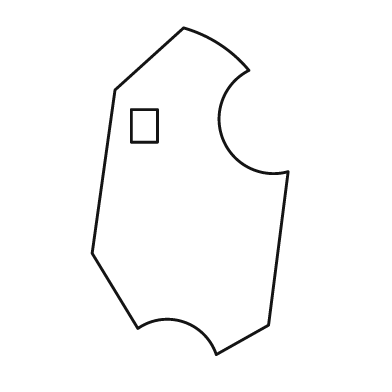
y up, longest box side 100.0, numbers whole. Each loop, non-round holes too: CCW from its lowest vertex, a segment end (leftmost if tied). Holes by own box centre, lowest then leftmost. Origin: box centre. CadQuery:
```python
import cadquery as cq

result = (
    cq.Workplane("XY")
    .moveTo(8.0, -50.0)
    .lineTo(24.0, -41.0)
    .lineTo(30.0, 6.0)
    .threePointArc((10.0, 16.0), (18.0, 37.0))
    .threePointArc((9.0, 45.0), (-2.0, 50.0))
    .lineTo(-23.0, 31.0)
    .lineTo(-30.0, -19.0)
    .lineTo(-16.0, -42.0)
    .threePointArc((-2.0, -40.0), (8.0, -50.0))
    .close()
    .moveTo(-18.0, 15.0)
    .lineTo(-10.0, 15.0)
    .lineTo(-10.0, 25.0)
    .lineTo(-18.0, 25.0)
    .close()
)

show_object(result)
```